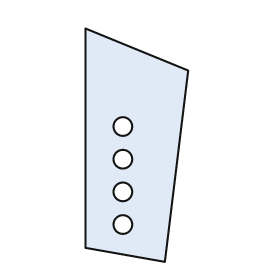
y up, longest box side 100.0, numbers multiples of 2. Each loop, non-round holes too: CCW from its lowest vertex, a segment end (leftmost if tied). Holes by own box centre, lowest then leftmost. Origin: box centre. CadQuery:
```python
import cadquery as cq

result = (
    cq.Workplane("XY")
    .moveTo(12.0, -50.0)
    .lineTo(22.0, 32.0)
    .lineTo(-22.0, 50.0)
    .lineTo(-22.0, -44.0)
    .close()
    .moveTo(-6.0, -34.0)
    .circle(4.0)
    .moveTo(-6.0, -20.0)
    .circle(4.0)
    .moveTo(-6.0, -6.0)
    .circle(4.0)
    .moveTo(-6.0, 8.0)
    .circle(4.0)
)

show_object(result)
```